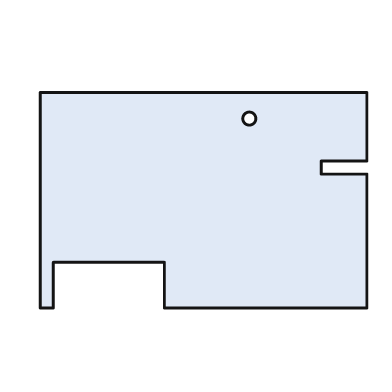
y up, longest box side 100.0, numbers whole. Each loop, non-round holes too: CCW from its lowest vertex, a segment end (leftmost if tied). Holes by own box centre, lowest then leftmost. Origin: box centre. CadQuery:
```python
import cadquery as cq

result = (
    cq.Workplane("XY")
    .moveTo(-50.0, -33.0)
    .lineTo(-46.0, -33.0)
    .lineTo(-46.0, -19.0)
    .lineTo(-12.0, -19.0)
    .lineTo(-12.0, -33.0)
    .lineTo(50.0, -33.0)
    .lineTo(50.0, 8.0)
    .lineTo(36.0, 8.0)
    .lineTo(36.0, 12.0)
    .lineTo(50.0, 12.0)
    .lineTo(50.0, 33.0)
    .lineTo(-50.0, 33.0)
    .close()
    .moveTo(14.0, 25.0)
    .circle(2.0)
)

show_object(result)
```